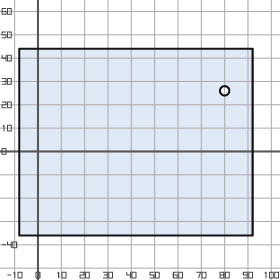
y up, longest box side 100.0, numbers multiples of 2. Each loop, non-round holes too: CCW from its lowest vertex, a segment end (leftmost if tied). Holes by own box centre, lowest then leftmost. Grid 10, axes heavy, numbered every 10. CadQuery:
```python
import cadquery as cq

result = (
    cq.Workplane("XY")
    .moveTo(-8.0, -36.0)
    .lineTo(92.0, -36.0)
    .lineTo(92.0, 44.0)
    .lineTo(-8.0, 44.0)
    .close()
    .moveTo(80.0, 26.0)
    .circle(2.0)
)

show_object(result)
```